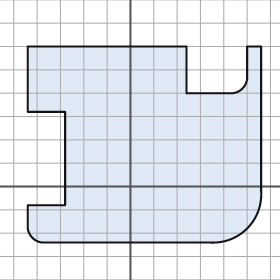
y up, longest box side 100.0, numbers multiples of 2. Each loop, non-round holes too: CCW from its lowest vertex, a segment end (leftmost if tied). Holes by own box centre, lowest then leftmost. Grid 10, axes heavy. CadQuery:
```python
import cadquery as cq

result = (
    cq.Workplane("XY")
    .moveTo(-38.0, -24.0)
    .lineTo(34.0, -24.0)
    .threePointArc((50.0, -18.0), (56.0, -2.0))
    .lineTo(56.0, 60.0)
    .lineTo(50.0, 60.0)
    .lineTo(50.0, 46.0)
    .threePointArc((48.0, 42.0), (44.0, 40.0))
    .lineTo(24.0, 40.0)
    .lineTo(24.0, 60.0)
    .lineTo(-44.0, 60.0)
    .lineTo(-44.0, 32.0)
    .lineTo(-28.0, 32.0)
    .lineTo(-28.0, -8.0)
    .lineTo(-44.0, -8.0)
    .lineTo(-44.0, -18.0)
    .threePointArc((-42.0, -22.0), (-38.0, -24.0))
    .close()
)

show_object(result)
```